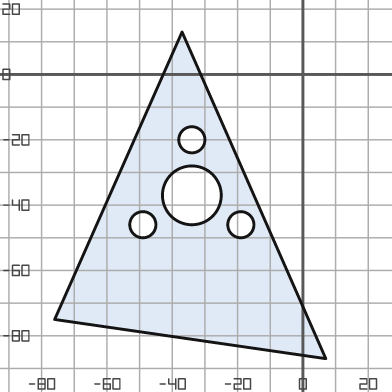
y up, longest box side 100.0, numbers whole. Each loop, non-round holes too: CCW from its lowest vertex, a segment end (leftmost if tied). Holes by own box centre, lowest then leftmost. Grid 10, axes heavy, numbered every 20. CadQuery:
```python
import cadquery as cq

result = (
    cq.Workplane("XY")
    .moveTo(7.0, -87.0)
    .lineTo(-37.0, 13.0)
    .lineTo(-76.0, -75.0)
    .close()
    .moveTo(-49.0, -46.0)
    .circle(4.0)
    .moveTo(-19.0, -46.0)
    .circle(4.0)
    .moveTo(-34.0, -37.0)
    .circle(9.0)
    .moveTo(-34.0, -20.0)
    .circle(4.0)
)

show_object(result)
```